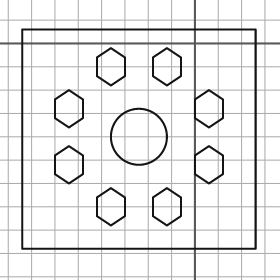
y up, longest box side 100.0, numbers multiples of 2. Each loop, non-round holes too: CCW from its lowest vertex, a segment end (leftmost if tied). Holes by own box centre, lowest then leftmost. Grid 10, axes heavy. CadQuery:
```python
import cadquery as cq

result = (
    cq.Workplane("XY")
    .moveTo(-74.0, -88.0)
    .lineTo(26.0, -88.0)
    .lineTo(26.0, 6.0)
    .lineTo(-74.0, 6.0)
    .close()
    .moveTo(-36.0, -78.0)
    .lineTo(-30.0, -74.0)
    .lineTo(-30.0, -66.0)
    .lineTo(-36.0, -62.0)
    .lineTo(-42.0, -66.0)
    .lineTo(-42.0, -74.0)
    .close()
    .moveTo(-12.0, -78.0)
    .lineTo(-6.0, -74.0)
    .lineTo(-6.0, -66.0)
    .lineTo(-12.0, -62.0)
    .lineTo(-18.0, -66.0)
    .lineTo(-18.0, -74.0)
    .close()
    .moveTo(-54.0, -60.0)
    .lineTo(-48.0, -56.0)
    .lineTo(-48.0, -48.0)
    .lineTo(-54.0, -44.0)
    .lineTo(-60.0, -48.0)
    .lineTo(-60.0, -56.0)
    .close()
    .moveTo(6.0, -60.0)
    .lineTo(12.0, -56.0)
    .lineTo(12.0, -48.0)
    .lineTo(6.0, -44.0)
    .lineTo(0.0, -48.0)
    .lineTo(0.0, -56.0)
    .close()
    .moveTo(-24.0, -40.0)
    .circle(12.0)
    .moveTo(-54.0, -36.0)
    .lineTo(-48.0, -32.0)
    .lineTo(-48.0, -24.0)
    .lineTo(-54.0, -20.0)
    .lineTo(-60.0, -24.0)
    .lineTo(-60.0, -32.0)
    .close()
    .moveTo(6.0, -36.0)
    .lineTo(12.0, -32.0)
    .lineTo(12.0, -24.0)
    .lineTo(6.0, -20.0)
    .lineTo(0.0, -24.0)
    .lineTo(0.0, -32.0)
    .close()
    .moveTo(-36.0, -18.0)
    .lineTo(-30.0, -14.0)
    .lineTo(-30.0, -6.0)
    .lineTo(-36.0, -2.0)
    .lineTo(-42.0, -6.0)
    .lineTo(-42.0, -14.0)
    .close()
    .moveTo(-12.0, -18.0)
    .lineTo(-6.0, -14.0)
    .lineTo(-6.0, -6.0)
    .lineTo(-12.0, -2.0)
    .lineTo(-18.0, -6.0)
    .lineTo(-18.0, -14.0)
    .close()
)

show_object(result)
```